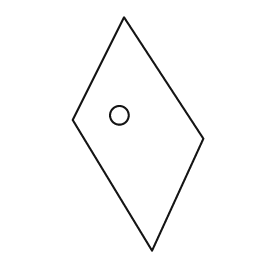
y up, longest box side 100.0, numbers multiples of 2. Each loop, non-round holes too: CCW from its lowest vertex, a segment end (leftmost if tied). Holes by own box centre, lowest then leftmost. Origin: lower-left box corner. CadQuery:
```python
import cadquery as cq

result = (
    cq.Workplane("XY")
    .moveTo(34.0, 0.0)
    .lineTo(56.0, 48.0)
    .lineTo(22.0, 100.0)
    .lineTo(0.0, 56.0)
    .close()
    .moveTo(20.0, 58.0)
    .circle(4.0)
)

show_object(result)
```